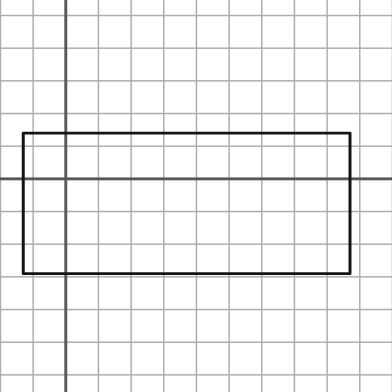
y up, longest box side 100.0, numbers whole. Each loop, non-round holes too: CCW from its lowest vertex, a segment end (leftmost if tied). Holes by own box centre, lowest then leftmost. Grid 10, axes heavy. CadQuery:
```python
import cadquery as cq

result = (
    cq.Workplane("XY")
    .moveTo(-13.0, -29.0)
    .lineTo(87.0, -29.0)
    .lineTo(87.0, 14.0)
    .lineTo(-13.0, 14.0)
    .close()
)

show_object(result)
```